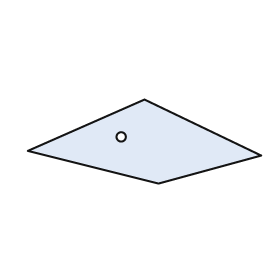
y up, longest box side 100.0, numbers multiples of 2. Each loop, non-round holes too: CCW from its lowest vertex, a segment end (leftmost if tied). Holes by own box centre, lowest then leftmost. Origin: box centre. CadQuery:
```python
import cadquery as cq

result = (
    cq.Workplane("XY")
    .moveTo(6.0, -18.0)
    .lineTo(50.0, -6.0)
    .lineTo(0.0, 18.0)
    .lineTo(-50.0, -4.0)
    .close()
    .moveTo(-10.0, 2.0)
    .circle(2.0)
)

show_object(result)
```